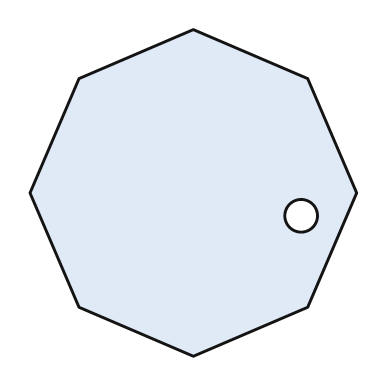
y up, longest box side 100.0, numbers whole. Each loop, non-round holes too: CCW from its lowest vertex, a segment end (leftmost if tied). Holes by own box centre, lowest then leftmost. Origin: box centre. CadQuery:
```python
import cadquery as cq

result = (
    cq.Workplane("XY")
    .moveTo(0.0, -50.0)
    .lineTo(35.0, -35.0)
    .lineTo(50.0, 0.0)
    .lineTo(35.0, 35.0)
    .lineTo(0.0, 50.0)
    .lineTo(-35.0, 35.0)
    .lineTo(-50.0, 0.0)
    .lineTo(-35.0, -35.0)
    .close()
    .moveTo(33.0, -7.0)
    .circle(5.0)
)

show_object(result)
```